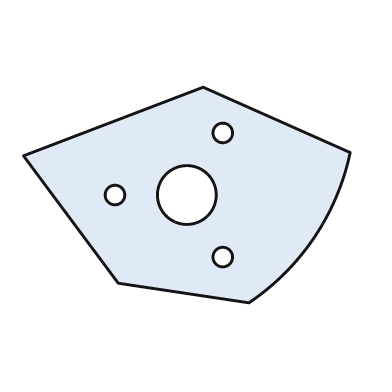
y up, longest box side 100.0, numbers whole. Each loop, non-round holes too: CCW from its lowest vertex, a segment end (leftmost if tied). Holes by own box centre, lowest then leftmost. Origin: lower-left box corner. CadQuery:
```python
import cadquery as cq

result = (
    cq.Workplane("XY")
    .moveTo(69.0, 0.0)
    .threePointArc((89.0, 20.0), (100.0, 46.0))
    .lineTo(55.0, 66.0)
    .lineTo(0.0, 45.0)
    .lineTo(29.0, 6.0)
    .close()
    .moveTo(61.0, 14.0)
    .circle(3.0)
    .moveTo(28.0, 33.0)
    .circle(3.0)
    .moveTo(50.0, 33.0)
    .circle(9.0)
    .moveTo(61.0, 52.0)
    .circle(3.0)
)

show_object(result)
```